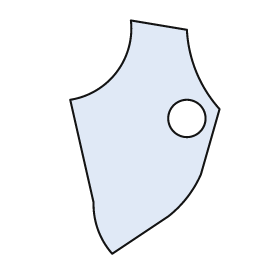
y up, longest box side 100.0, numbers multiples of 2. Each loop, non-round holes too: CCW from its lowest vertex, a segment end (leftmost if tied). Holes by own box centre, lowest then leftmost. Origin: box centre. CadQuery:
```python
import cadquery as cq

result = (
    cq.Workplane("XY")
    .moveTo(-14.0, -50.0)
    .lineTo(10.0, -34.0)
    .threePointArc((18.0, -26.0), (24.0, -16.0))
    .lineTo(32.0, 12.0)
    .threePointArc((22.0, 28.0), (18.0, 46.0))
    .lineTo(-6.0, 50.0)
    .threePointArc((-12.0, 28.0), (-32.0, 16.0))
    .lineTo(-22.0, -28.0)
    .threePointArc((-20.0, -40.0), (-14.0, -50.0))
    .close()
    .moveTo(18.0, 8.0)
    .circle(8.0)
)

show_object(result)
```